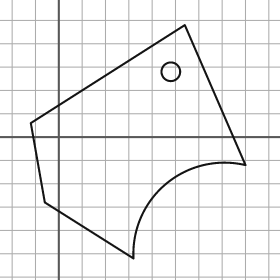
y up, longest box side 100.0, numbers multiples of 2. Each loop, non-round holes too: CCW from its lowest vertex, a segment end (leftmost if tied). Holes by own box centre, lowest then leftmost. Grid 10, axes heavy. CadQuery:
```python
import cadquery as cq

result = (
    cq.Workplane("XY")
    .moveTo(32.0, -52.0)
    .threePointArc((46.0, -20.0), (80.0, -12.0))
    .lineTo(54.0, 48.0)
    .lineTo(-12.0, 6.0)
    .lineTo(-6.0, -28.0)
    .close()
    .moveTo(48.0, 28.0)
    .circle(4.0)
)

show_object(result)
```